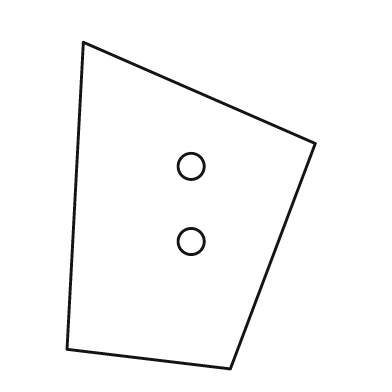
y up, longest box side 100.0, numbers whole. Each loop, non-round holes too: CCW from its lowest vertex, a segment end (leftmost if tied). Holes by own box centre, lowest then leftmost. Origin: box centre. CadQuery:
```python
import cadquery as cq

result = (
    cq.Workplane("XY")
    .moveTo(12.0, -50.0)
    .lineTo(38.0, 19.0)
    .lineTo(-33.0, 50.0)
    .lineTo(-38.0, -44.0)
    .close()
    .moveTo(0.0, -11.0)
    .circle(4.0)
    .moveTo(0.0, 12.0)
    .circle(4.0)
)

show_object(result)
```